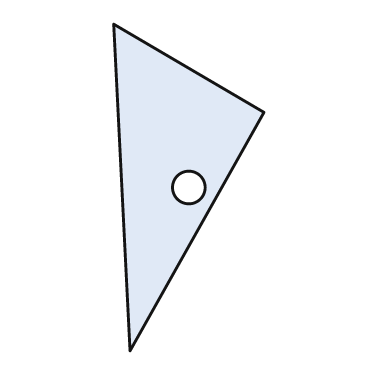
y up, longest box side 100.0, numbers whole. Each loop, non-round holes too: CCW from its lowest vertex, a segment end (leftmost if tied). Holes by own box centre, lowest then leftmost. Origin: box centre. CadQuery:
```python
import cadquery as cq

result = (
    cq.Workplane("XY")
    .moveTo(-18.0, -50.0)
    .lineTo(23.0, 23.0)
    .lineTo(-23.0, 50.0)
    .close()
    .moveTo(0.0, 0.0)
    .circle(5.0)
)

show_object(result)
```